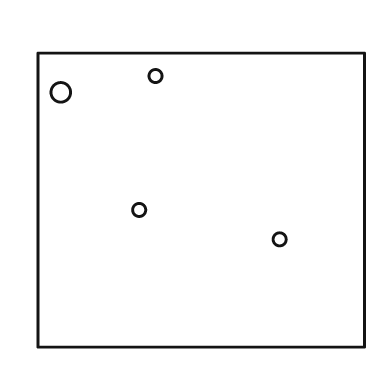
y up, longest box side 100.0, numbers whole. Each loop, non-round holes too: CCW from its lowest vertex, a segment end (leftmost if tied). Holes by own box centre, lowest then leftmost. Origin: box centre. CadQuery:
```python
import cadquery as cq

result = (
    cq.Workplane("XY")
    .moveTo(-50.0, -45.0)
    .lineTo(50.0, -45.0)
    .lineTo(50.0, 45.0)
    .lineTo(-50.0, 45.0)
    .close()
    .moveTo(24.0, -12.0)
    .circle(2.0)
    .moveTo(-19.0, -3.0)
    .circle(2.0)
    .moveTo(-43.0, 33.0)
    .circle(3.0)
    .moveTo(-14.0, 38.0)
    .circle(2.0)
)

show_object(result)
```